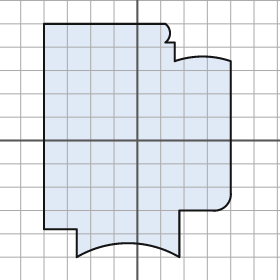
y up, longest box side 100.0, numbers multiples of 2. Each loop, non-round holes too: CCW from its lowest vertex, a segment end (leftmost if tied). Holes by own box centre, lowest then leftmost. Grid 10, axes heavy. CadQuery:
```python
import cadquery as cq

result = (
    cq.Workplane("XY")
    .moveTo(-26.0, -50.0)
    .threePointArc((-4.0, -44.0), (18.0, -50.0))
    .lineTo(18.0, -30.0)
    .lineTo(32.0, -30.0)
    .threePointArc((38.0, -28.0), (40.0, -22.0))
    .lineTo(40.0, 34.0)
    .threePointArc((28.0, 36.0), (16.0, 34.0))
    .lineTo(16.0, 42.0)
    .lineTo(12.0, 42.0)
    .threePointArc((14.0, 46.0), (12.0, 50.0))
    .lineTo(-40.0, 50.0)
    .lineTo(-40.0, -38.0)
    .lineTo(-26.0, -38.0)
    .close()
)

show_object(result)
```